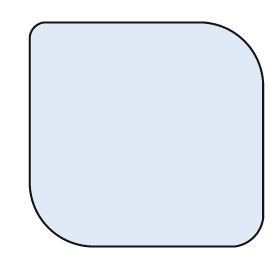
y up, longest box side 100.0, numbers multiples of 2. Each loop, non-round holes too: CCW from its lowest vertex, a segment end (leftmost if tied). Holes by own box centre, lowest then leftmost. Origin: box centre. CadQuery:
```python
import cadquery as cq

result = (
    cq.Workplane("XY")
    .moveTo(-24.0, -48.0)
    .lineTo(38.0, -48.0)
    .threePointArc((46.0, -44.0), (50.0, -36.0))
    .lineTo(50.0, 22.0)
    .threePointArc((42.0, 40.0), (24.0, 48.0))
    .lineTo(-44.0, 48.0)
    .threePointArc((-48.0, 46.0), (-50.0, 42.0))
    .lineTo(-50.0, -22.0)
    .threePointArc((-42.0, -40.0), (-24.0, -48.0))
    .close()
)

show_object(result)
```